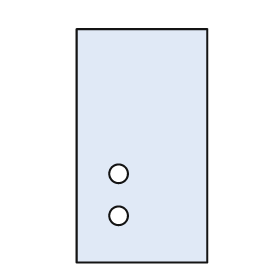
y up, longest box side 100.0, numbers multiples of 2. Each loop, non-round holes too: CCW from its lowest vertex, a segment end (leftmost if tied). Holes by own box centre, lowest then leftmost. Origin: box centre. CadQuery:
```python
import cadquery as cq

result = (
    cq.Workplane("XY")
    .moveTo(-28.0, -50.0)
    .lineTo(28.0, -50.0)
    .lineTo(28.0, 50.0)
    .lineTo(-28.0, 50.0)
    .close()
    .moveTo(-10.0, -30.0)
    .circle(4.0)
    .moveTo(-10.0, -12.0)
    .circle(4.0)
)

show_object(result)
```